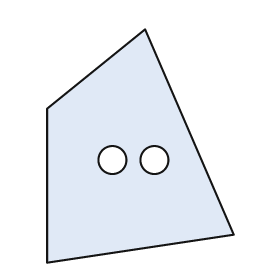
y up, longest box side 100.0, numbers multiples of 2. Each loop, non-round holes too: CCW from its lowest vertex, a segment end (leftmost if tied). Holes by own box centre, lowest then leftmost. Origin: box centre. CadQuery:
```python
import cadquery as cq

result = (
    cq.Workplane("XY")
    .moveTo(-40.0, -50.0)
    .lineTo(40.0, -38.0)
    .lineTo(2.0, 50.0)
    .lineTo(-40.0, 16.0)
    .close()
    .moveTo(-12.0, -6.0)
    .circle(6.0)
    .moveTo(6.0, -6.0)
    .circle(6.0)
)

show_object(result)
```